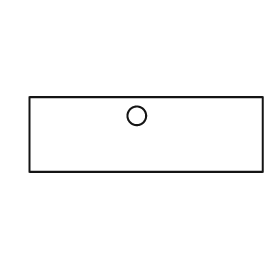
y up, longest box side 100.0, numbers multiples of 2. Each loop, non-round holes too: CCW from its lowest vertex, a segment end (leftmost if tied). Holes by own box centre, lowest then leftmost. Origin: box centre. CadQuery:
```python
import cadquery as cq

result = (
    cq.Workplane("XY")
    .moveTo(-50.0, -16.0)
    .lineTo(50.0, -16.0)
    .lineTo(50.0, 16.0)
    .lineTo(-50.0, 16.0)
    .close()
    .moveTo(-4.0, 8.0)
    .circle(4.0)
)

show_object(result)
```